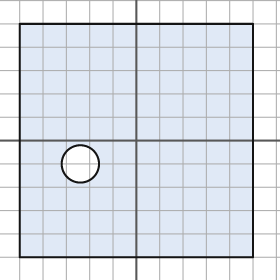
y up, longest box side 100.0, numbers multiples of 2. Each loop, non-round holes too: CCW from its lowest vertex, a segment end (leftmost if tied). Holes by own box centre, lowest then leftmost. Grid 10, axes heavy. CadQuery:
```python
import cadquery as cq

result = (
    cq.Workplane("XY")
    .moveTo(-50.0, -50.0)
    .lineTo(50.0, -50.0)
    .lineTo(50.0, 50.0)
    .lineTo(-50.0, 50.0)
    .close()
    .moveTo(-24.0, -10.0)
    .circle(8.0)
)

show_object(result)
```